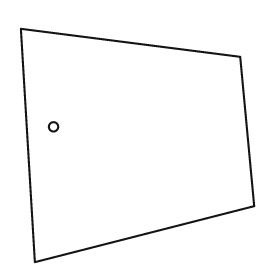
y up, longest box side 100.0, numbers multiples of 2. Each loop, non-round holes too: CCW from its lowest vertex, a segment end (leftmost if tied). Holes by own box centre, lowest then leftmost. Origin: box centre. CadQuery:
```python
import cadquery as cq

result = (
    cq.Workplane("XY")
    .moveTo(-44.0, -50.0)
    .lineTo(50.0, -26.0)
    .lineTo(44.0, 38.0)
    .lineTo(-50.0, 50.0)
    .close()
    .moveTo(-36.0, 8.0)
    .circle(2.0)
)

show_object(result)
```